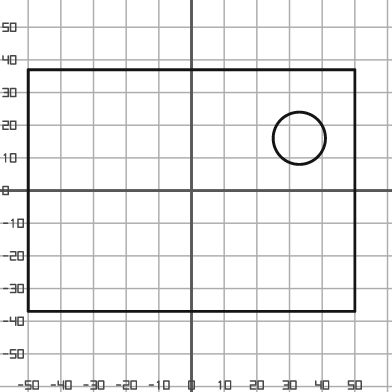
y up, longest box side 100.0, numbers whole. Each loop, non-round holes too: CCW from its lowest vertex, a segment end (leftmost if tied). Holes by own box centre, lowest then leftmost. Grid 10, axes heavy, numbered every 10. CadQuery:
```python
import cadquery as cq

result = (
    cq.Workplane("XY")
    .moveTo(-50.0, -37.0)
    .lineTo(50.0, -37.0)
    .lineTo(50.0, 37.0)
    .lineTo(-50.0, 37.0)
    .close()
    .moveTo(33.0, 16.0)
    .circle(8.0)
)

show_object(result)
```